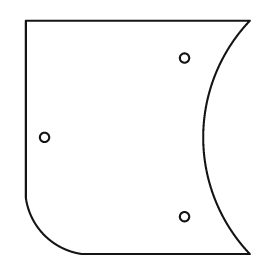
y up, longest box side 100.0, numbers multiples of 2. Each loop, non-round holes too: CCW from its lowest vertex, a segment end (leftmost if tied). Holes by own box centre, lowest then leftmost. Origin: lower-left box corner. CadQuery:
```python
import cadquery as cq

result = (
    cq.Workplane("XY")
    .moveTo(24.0, 0.0)
    .lineTo(96.0, 0.0)
    .threePointArc((76.0, 50.0), (96.0, 100.0))
    .lineTo(0.0, 100.0)
    .lineTo(0.0, 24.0)
    .threePointArc((8.0, 8.0), (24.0, 0.0))
    .close()
    .moveTo(68.0, 16.0)
    .circle(2.0)
    .moveTo(8.0, 50.0)
    .circle(2.0)
    .moveTo(68.0, 84.0)
    .circle(2.0)
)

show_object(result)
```